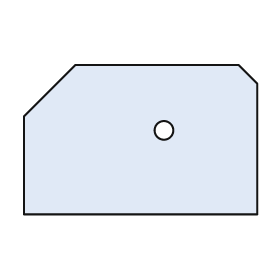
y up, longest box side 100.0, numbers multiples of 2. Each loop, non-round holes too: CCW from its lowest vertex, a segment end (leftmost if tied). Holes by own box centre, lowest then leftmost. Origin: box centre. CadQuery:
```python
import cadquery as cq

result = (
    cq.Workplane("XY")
    .moveTo(-50.0, -32.0)
    .lineTo(50.0, -32.0)
    .lineTo(50.0, 24.0)
    .lineTo(42.0, 32.0)
    .lineTo(-28.0, 32.0)
    .lineTo(-50.0, 10.0)
    .close()
    .moveTo(10.0, 4.0)
    .circle(4.0)
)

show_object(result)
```